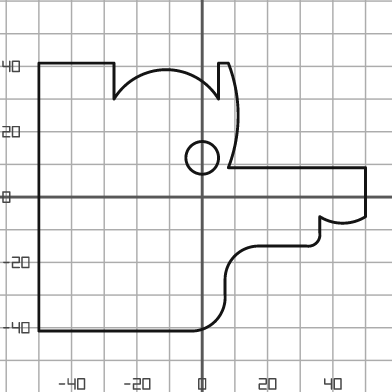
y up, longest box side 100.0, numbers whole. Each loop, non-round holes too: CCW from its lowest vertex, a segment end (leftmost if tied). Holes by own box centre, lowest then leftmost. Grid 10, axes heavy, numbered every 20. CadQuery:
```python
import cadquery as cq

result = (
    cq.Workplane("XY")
    .moveTo(-50.0, -41.0)
    .lineTo(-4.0, -41.0)
    .threePointArc((4.0, -38.0), (7.0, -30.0))
    .lineTo(7.0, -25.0)
    .threePointArc((10.0, -18.0), (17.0, -15.0))
    .lineTo(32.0, -15.0)
    .threePointArc((35.0, -14.0), (36.0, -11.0))
    .lineTo(36.0, -6.0)
    .threePointArc((43.0, -8.0), (50.0, -6.0))
    .lineTo(50.0, 9.0)
    .lineTo(8.0, 9.0)
    .threePointArc((11.0, 25.0), (8.0, 41.0))
    .lineTo(5.0, 41.0)
    .lineTo(5.0, 30.0)
    .threePointArc((-11.0, 39.0), (-27.0, 30.0))
    .lineTo(-27.0, 41.0)
    .lineTo(-50.0, 41.0)
    .close()
    .moveTo(0.0, 12.0)
    .circle(5.0)
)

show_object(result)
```